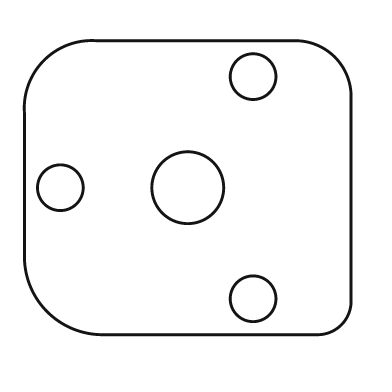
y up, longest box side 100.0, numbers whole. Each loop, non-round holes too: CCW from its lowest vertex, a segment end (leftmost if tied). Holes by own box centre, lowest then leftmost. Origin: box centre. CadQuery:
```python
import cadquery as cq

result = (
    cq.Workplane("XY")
    .moveTo(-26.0, -45.0)
    .lineTo(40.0, -45.0)
    .threePointArc((47.0, -42.0), (50.0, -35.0))
    .lineTo(50.0, 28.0)
    .threePointArc((45.0, 40.0), (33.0, 45.0))
    .lineTo(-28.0, 45.0)
    .threePointArc((-44.0, 39.0), (-50.0, 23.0))
    .lineTo(-50.0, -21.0)
    .threePointArc((-43.0, -38.0), (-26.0, -45.0))
    .close()
    .moveTo(20.0, -34.0)
    .circle(7.0)
    .moveTo(-39.0, 0.0)
    .circle(7.0)
    .moveTo(0.0, 0.0)
    .circle(11.0)
    .moveTo(20.0, 34.0)
    .circle(7.0)
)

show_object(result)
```